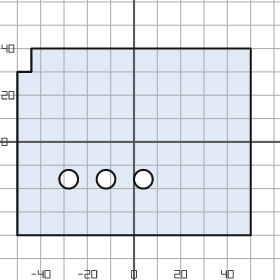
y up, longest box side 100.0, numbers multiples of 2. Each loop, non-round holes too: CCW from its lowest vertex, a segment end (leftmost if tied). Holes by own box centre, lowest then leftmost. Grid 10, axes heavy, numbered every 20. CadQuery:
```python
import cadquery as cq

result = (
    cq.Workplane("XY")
    .moveTo(-50.0, -40.0)
    .lineTo(50.0, -40.0)
    .lineTo(50.0, 40.0)
    .lineTo(-44.0, 40.0)
    .lineTo(-44.0, 30.0)
    .lineTo(-50.0, 30.0)
    .close()
    .moveTo(-28.0, -16.0)
    .circle(4.0)
    .moveTo(-12.0, -16.0)
    .circle(4.0)
    .moveTo(4.0, -16.0)
    .circle(4.0)
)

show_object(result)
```